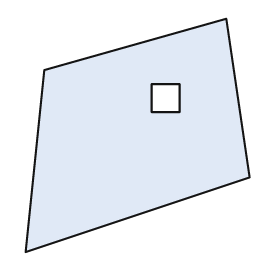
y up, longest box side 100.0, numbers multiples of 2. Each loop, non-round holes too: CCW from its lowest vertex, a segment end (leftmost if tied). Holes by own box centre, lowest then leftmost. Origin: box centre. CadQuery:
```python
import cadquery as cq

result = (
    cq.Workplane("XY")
    .moveTo(-48.0, -50.0)
    .lineTo(48.0, -18.0)
    .lineTo(38.0, 50.0)
    .lineTo(-40.0, 28.0)
    .close()
    .moveTo(6.0, 10.0)
    .lineTo(18.0, 10.0)
    .lineTo(18.0, 22.0)
    .lineTo(6.0, 22.0)
    .close()
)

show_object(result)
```